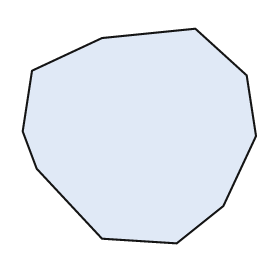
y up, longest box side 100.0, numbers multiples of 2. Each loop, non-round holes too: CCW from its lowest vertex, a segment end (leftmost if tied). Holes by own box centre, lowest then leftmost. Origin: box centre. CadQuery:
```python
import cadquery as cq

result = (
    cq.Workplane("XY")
    .moveTo(16.0, -46.0)
    .lineTo(36.0, -30.0)
    .lineTo(50.0, 0.0)
    .lineTo(46.0, 26.0)
    .lineTo(24.0, 46.0)
    .lineTo(-16.0, 42.0)
    .lineTo(-46.0, 28.0)
    .lineTo(-50.0, 2.0)
    .lineTo(-44.0, -14.0)
    .lineTo(-16.0, -44.0)
    .close()
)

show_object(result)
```